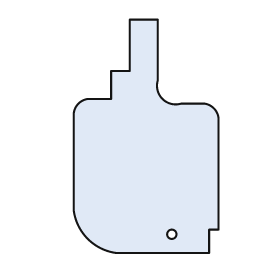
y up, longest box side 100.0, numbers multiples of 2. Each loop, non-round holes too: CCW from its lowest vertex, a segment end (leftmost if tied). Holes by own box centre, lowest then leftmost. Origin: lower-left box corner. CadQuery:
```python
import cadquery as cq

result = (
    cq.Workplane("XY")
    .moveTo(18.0, 0.0)
    .lineTo(58.0, 0.0)
    .lineTo(58.0, 10.0)
    .lineTo(62.0, 10.0)
    .lineTo(62.0, 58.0)
    .threePointArc((60.0, 62.0), (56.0, 64.0))
    .lineTo(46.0, 64.0)
    .threePointArc((38.0, 66.0), (36.0, 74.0))
    .lineTo(36.0, 100.0)
    .lineTo(24.0, 100.0)
    .lineTo(24.0, 78.0)
    .lineTo(16.0, 78.0)
    .lineTo(16.0, 66.0)
    .lineTo(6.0, 66.0)
    .threePointArc((2.0, 64.0), (0.0, 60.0))
    .lineTo(0.0, 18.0)
    .threePointArc((6.0, 6.0), (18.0, 0.0))
    .close()
    .moveTo(42.0, 8.0)
    .circle(2.0)
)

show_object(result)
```